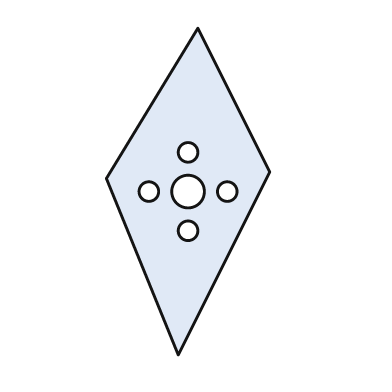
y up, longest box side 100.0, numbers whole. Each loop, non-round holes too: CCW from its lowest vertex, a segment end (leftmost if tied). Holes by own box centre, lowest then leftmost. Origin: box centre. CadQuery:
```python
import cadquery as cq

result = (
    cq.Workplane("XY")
    .moveTo(-3.0, -50.0)
    .lineTo(25.0, 6.0)
    .lineTo(3.0, 50.0)
    .lineTo(-25.0, 4.0)
    .close()
    .moveTo(0.0, -12.0)
    .circle(3.0)
    .moveTo(-12.0, 0.0)
    .circle(3.0)
    .moveTo(0.0, 0.0)
    .circle(5.0)
    .moveTo(12.0, 0.0)
    .circle(3.0)
    .moveTo(0.0, 12.0)
    .circle(3.0)
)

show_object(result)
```